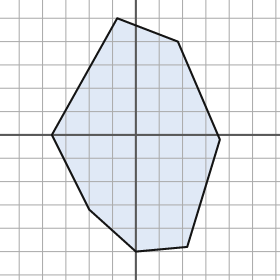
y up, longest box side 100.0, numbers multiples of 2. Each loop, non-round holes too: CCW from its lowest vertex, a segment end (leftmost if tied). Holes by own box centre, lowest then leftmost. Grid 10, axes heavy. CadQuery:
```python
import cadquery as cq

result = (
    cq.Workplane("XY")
    .moveTo(0.0, -50.0)
    .lineTo(22.0, -48.0)
    .lineTo(36.0, -2.0)
    .lineTo(18.0, 40.0)
    .lineTo(-8.0, 50.0)
    .lineTo(-36.0, 0.0)
    .lineTo(-20.0, -32.0)
    .close()
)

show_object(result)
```